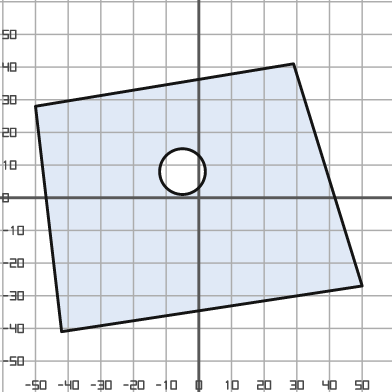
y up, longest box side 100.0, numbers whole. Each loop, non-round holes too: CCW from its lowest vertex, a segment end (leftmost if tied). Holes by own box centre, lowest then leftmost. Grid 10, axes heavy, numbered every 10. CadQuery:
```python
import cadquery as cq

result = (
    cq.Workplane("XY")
    .moveTo(-42.0, -41.0)
    .lineTo(50.0, -27.0)
    .lineTo(29.0, 41.0)
    .lineTo(-50.0, 28.0)
    .close()
    .moveTo(-5.0, 8.0)
    .circle(7.0)
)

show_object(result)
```